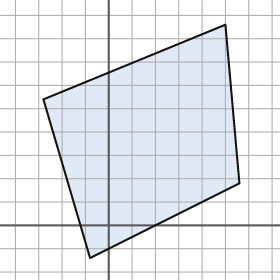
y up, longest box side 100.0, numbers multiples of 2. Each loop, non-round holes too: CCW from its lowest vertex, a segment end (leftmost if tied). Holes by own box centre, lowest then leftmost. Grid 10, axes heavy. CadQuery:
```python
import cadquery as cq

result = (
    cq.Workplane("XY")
    .moveTo(-8.0, -14.0)
    .lineTo(56.0, 18.0)
    .lineTo(50.0, 86.0)
    .lineTo(-28.0, 54.0)
    .close()
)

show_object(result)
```